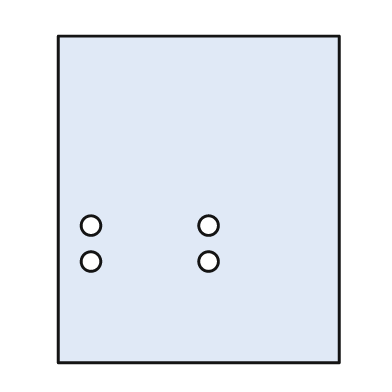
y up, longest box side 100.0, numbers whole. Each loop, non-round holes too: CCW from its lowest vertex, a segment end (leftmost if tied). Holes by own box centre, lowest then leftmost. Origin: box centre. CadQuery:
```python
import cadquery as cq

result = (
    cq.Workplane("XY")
    .moveTo(-43.0, -50.0)
    .lineTo(43.0, -50.0)
    .lineTo(43.0, 50.0)
    .lineTo(-43.0, 50.0)
    .close()
    .moveTo(-33.0, -19.0)
    .circle(3.0)
    .moveTo(3.0, -19.0)
    .circle(3.0)
    .moveTo(-33.0, -8.0)
    .circle(3.0)
    .moveTo(3.0, -8.0)
    .circle(3.0)
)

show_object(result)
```